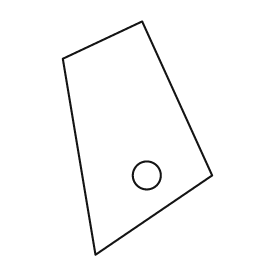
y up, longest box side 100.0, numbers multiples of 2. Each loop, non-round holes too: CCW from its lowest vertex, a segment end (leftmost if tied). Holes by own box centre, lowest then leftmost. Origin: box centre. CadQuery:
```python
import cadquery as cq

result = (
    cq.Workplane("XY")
    .moveTo(-18.0, -50.0)
    .lineTo(32.0, -16.0)
    .lineTo(2.0, 50.0)
    .lineTo(-32.0, 34.0)
    .close()
    .moveTo(4.0, -16.0)
    .circle(6.0)
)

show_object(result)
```